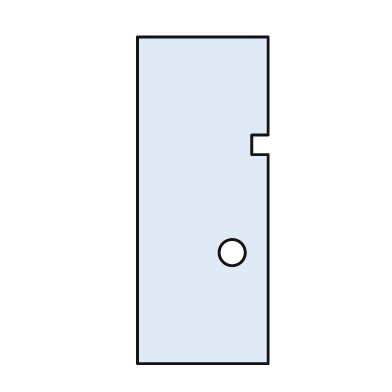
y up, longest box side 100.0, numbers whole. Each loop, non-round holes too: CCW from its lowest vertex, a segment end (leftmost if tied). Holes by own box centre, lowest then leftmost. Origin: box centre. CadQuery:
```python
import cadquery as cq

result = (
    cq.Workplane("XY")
    .moveTo(-20.0, -50.0)
    .lineTo(20.0, -50.0)
    .lineTo(20.0, 14.0)
    .lineTo(15.0, 14.0)
    .lineTo(15.0, 20.0)
    .lineTo(20.0, 20.0)
    .lineTo(20.0, 50.0)
    .lineTo(-20.0, 50.0)
    .close()
    .moveTo(9.0, -16.0)
    .circle(4.0)
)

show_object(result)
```